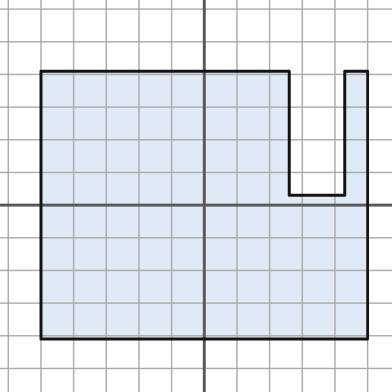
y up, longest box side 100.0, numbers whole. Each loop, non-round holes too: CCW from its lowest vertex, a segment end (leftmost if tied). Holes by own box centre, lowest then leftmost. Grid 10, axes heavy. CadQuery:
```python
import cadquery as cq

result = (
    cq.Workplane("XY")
    .moveTo(-50.0, -41.0)
    .lineTo(50.0, -41.0)
    .lineTo(50.0, 41.0)
    .lineTo(43.0, 41.0)
    .lineTo(43.0, 3.0)
    .lineTo(26.0, 3.0)
    .lineTo(26.0, 41.0)
    .lineTo(-50.0, 41.0)
    .close()
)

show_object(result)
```